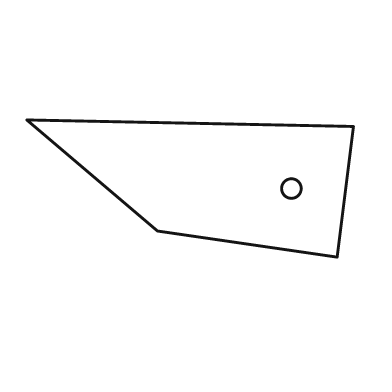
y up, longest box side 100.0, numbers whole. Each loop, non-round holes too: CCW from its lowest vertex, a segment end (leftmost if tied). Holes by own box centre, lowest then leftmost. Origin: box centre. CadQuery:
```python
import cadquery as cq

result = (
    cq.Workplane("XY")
    .moveTo(45.0, -21.0)
    .lineTo(50.0, 19.0)
    .lineTo(-50.0, 21.0)
    .lineTo(-10.0, -13.0)
    .close()
    .moveTo(31.0, 0.0)
    .circle(3.0)
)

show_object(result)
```